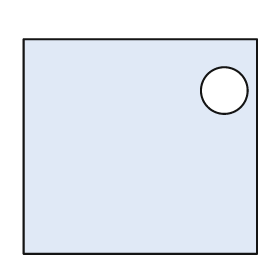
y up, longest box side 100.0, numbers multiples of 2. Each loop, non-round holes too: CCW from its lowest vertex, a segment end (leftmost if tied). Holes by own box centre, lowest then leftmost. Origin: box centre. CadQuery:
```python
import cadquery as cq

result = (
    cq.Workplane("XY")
    .moveTo(-50.0, -46.0)
    .lineTo(50.0, -46.0)
    .lineTo(50.0, 46.0)
    .lineTo(-50.0, 46.0)
    .close()
    .moveTo(36.0, 24.0)
    .circle(10.0)
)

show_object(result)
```